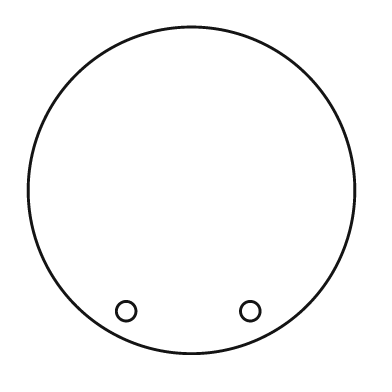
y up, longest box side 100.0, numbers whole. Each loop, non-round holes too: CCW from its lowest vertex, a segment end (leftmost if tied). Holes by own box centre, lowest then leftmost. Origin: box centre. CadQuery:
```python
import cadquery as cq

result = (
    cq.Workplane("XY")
    .moveTo(0.0, 0.0)
    .circle(50.0)
    .moveTo(-20.0, -37.0)
    .circle(3.0)
    .moveTo(18.0, -37.0)
    .circle(3.0)
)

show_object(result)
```